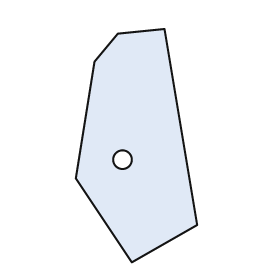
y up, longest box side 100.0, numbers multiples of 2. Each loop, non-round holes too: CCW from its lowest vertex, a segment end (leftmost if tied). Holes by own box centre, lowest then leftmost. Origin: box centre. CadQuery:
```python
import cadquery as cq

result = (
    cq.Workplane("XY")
    .moveTo(-2.0, -50.0)
    .lineTo(26.0, -34.0)
    .lineTo(12.0, 50.0)
    .lineTo(-8.0, 48.0)
    .lineTo(-18.0, 36.0)
    .lineTo(-26.0, -14.0)
    .close()
    .moveTo(-6.0, -6.0)
    .circle(4.0)
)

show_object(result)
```